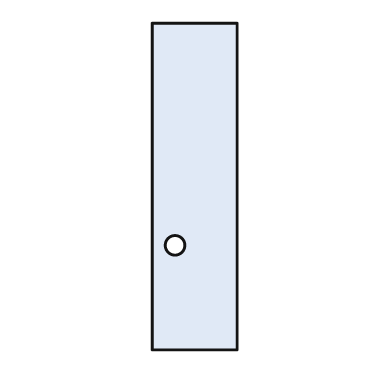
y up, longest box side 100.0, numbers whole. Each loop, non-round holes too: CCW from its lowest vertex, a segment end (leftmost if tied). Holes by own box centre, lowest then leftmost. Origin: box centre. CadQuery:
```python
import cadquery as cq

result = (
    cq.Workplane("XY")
    .moveTo(-13.0, -50.0)
    .lineTo(13.0, -50.0)
    .lineTo(13.0, 50.0)
    .lineTo(-13.0, 50.0)
    .close()
    .moveTo(-6.0, -18.0)
    .circle(3.0)
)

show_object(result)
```